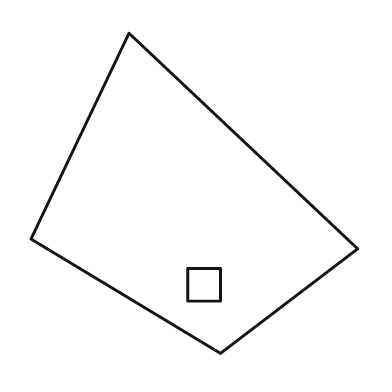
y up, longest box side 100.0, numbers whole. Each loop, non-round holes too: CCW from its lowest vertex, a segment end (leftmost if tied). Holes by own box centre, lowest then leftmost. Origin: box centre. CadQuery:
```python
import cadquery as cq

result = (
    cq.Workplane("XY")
    .moveTo(8.0, -49.0)
    .lineTo(50.0, -17.0)
    .lineTo(-20.0, 49.0)
    .lineTo(-50.0, -14.0)
    .close()
    .moveTo(-2.0, -33.0)
    .lineTo(8.0, -33.0)
    .lineTo(8.0, -23.0)
    .lineTo(-2.0, -23.0)
    .close()
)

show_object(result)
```